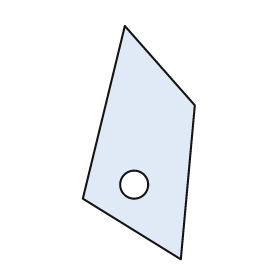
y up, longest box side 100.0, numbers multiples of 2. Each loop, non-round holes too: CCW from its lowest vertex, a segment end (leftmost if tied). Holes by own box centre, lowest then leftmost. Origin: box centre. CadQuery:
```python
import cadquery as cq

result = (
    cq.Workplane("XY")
    .moveTo(18.0, -50.0)
    .lineTo(24.0, 16.0)
    .lineTo(-6.0, 50.0)
    .lineTo(-24.0, -24.0)
    .close()
    .moveTo(-2.0, -18.0)
    .circle(6.0)
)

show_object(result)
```